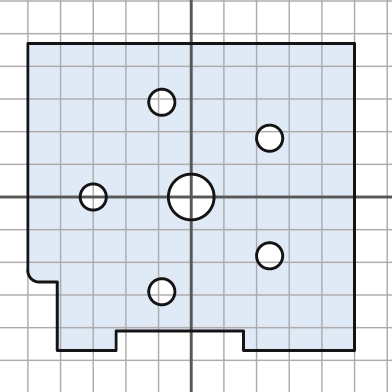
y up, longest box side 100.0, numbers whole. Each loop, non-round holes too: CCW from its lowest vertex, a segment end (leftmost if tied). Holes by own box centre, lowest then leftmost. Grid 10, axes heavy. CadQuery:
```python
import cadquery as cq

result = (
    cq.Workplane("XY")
    .moveTo(-41.0, -47.0)
    .lineTo(-23.0, -47.0)
    .lineTo(-23.0, -41.0)
    .lineTo(16.0, -41.0)
    .lineTo(16.0, -47.0)
    .lineTo(50.0, -47.0)
    .lineTo(50.0, 47.0)
    .lineTo(-50.0, 47.0)
    .lineTo(-50.0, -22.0)
    .threePointArc((-49.0, -25.0), (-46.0, -26.0))
    .lineTo(-41.0, -26.0)
    .close()
    .moveTo(-9.0, -29.0)
    .circle(4.0)
    .moveTo(24.0, -18.0)
    .circle(4.0)
    .moveTo(-30.0, 0.0)
    .circle(4.0)
    .moveTo(0.0, 0.0)
    .circle(7.0)
    .moveTo(24.0, 18.0)
    .circle(4.0)
    .moveTo(-9.0, 29.0)
    .circle(4.0)
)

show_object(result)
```